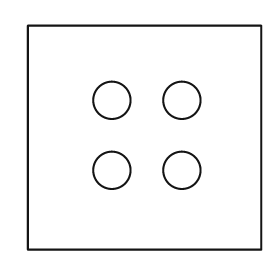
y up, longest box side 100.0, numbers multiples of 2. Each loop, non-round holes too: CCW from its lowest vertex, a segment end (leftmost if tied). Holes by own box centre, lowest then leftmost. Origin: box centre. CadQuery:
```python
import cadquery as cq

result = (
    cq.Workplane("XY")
    .moveTo(-50.0, -48.0)
    .lineTo(50.0, -48.0)
    .lineTo(50.0, 48.0)
    .lineTo(-50.0, 48.0)
    .close()
    .moveTo(-14.0, -14.0)
    .circle(8.0)
    .moveTo(16.0, -14.0)
    .circle(8.0)
    .moveTo(-14.0, 16.0)
    .circle(8.0)
    .moveTo(16.0, 16.0)
    .circle(8.0)
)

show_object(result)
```